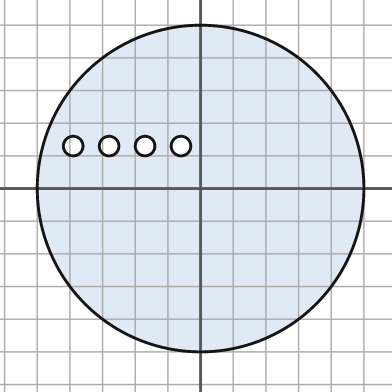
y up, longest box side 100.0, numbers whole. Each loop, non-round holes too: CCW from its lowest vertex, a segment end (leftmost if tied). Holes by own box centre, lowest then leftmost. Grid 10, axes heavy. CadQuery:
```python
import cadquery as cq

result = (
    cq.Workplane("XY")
    .moveTo(0.0, 0.0)
    .circle(50.0)
    .moveTo(-39.0, 13.0)
    .circle(3.0)
    .moveTo(-28.0, 13.0)
    .circle(3.0)
    .moveTo(-17.0, 13.0)
    .circle(3.0)
    .moveTo(-6.0, 13.0)
    .circle(3.0)
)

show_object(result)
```